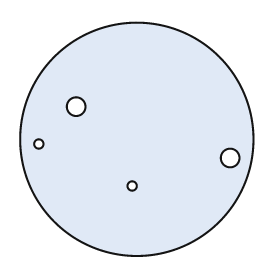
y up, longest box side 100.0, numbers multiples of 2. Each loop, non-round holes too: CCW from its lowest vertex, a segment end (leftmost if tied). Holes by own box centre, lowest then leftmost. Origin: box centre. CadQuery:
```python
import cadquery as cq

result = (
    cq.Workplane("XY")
    .moveTo(0.0, 0.0)
    .circle(50.0)
    .moveTo(-2.0, -20.0)
    .circle(2.0)
    .moveTo(40.0, -8.0)
    .circle(4.0)
    .moveTo(-42.0, -2.0)
    .circle(2.0)
    .moveTo(-26.0, 14.0)
    .circle(4.0)
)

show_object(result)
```